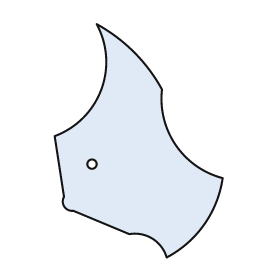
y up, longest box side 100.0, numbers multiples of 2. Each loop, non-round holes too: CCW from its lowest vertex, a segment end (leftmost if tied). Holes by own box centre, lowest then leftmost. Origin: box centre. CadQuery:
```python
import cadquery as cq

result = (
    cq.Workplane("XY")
    .moveTo(12.0, -50.0)
    .threePointArc((28.0, -36.0), (36.0, -16.0))
    .threePointArc((16.0, -2.0), (10.0, 22.0))
    .threePointArc((-2.0, 38.0), (-18.0, 50.0))
    .threePointArc((-16.0, 22.0), (-36.0, 2.0))
    .lineTo(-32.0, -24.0)
    .threePointArc((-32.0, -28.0), (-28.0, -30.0))
    .lineTo(-4.0, -40.0)
    .threePointArc((6.0, -42.0), (12.0, -50.0))
    .close()
    .moveTo(-20.0, -10.0)
    .circle(2.0)
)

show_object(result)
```